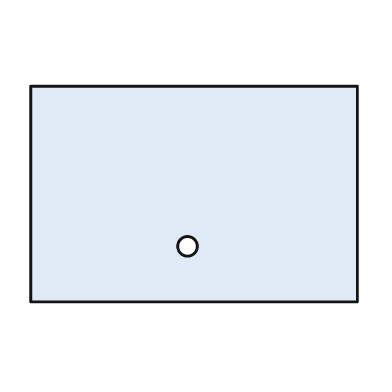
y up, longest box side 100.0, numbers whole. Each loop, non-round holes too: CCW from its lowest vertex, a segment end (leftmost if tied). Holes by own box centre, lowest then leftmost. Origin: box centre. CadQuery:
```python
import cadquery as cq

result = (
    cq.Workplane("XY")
    .moveTo(-50.0, -33.0)
    .lineTo(50.0, -33.0)
    .lineTo(50.0, 33.0)
    .lineTo(-50.0, 33.0)
    .close()
    .moveTo(-2.0, -16.0)
    .circle(3.0)
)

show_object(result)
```